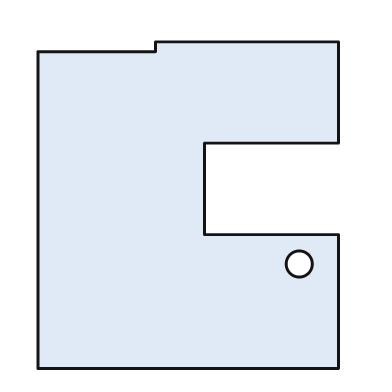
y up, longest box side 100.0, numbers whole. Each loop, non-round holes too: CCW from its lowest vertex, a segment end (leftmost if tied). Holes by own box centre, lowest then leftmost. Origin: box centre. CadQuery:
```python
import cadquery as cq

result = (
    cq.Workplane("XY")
    .moveTo(-46.0, -50.0)
    .lineTo(46.0, -50.0)
    .lineTo(46.0, -9.0)
    .lineTo(5.0, -9.0)
    .lineTo(5.0, 19.0)
    .lineTo(46.0, 19.0)
    .lineTo(46.0, 50.0)
    .lineTo(-10.0, 50.0)
    .lineTo(-10.0, 47.0)
    .lineTo(-46.0, 47.0)
    .close()
    .moveTo(34.0, -18.0)
    .circle(4.0)
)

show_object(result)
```